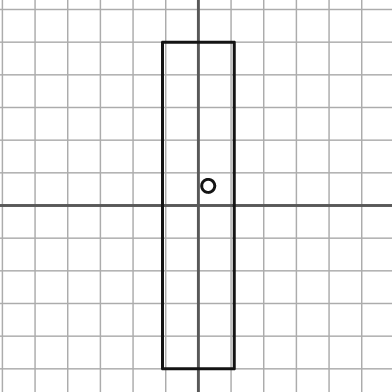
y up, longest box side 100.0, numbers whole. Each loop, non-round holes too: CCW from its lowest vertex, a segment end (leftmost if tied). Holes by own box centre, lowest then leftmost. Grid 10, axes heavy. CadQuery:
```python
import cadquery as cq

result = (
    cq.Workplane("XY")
    .moveTo(-11.0, -50.0)
    .lineTo(11.0, -50.0)
    .lineTo(11.0, 50.0)
    .lineTo(-11.0, 50.0)
    .close()
    .moveTo(3.0, 6.0)
    .circle(2.0)
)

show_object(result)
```